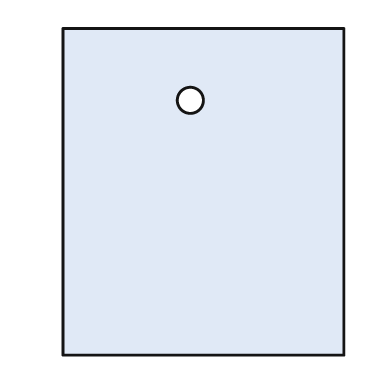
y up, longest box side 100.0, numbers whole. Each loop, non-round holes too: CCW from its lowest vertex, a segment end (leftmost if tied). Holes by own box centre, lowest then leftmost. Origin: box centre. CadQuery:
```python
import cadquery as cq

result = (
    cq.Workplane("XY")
    .moveTo(-43.0, -50.0)
    .lineTo(43.0, -50.0)
    .lineTo(43.0, 50.0)
    .lineTo(-43.0, 50.0)
    .close()
    .moveTo(-4.0, 28.0)
    .circle(4.0)
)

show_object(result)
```